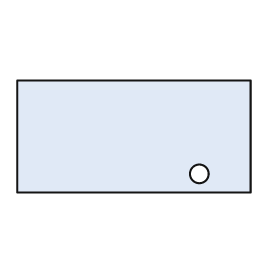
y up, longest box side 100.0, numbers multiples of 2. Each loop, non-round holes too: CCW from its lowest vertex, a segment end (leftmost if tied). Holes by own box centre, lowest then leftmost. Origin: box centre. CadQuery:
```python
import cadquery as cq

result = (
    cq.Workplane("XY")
    .moveTo(-50.0, -24.0)
    .lineTo(50.0, -24.0)
    .lineTo(50.0, 24.0)
    .lineTo(-50.0, 24.0)
    .close()
    .moveTo(28.0, -16.0)
    .circle(4.0)
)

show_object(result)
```